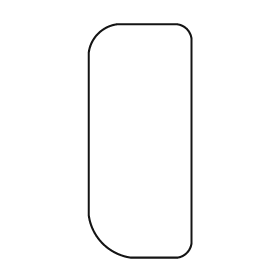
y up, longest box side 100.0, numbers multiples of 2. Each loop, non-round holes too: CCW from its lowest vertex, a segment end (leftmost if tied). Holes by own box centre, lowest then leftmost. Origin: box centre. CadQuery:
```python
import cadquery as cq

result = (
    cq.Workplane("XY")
    .moveTo(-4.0, -50.0)
    .lineTo(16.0, -50.0)
    .threePointArc((20.0, -48.0), (22.0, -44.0))
    .lineTo(22.0, 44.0)
    .threePointArc((20.0, 48.0), (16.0, 50.0))
    .lineTo(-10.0, 50.0)
    .threePointArc((-18.0, 46.0), (-22.0, 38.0))
    .lineTo(-22.0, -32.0)
    .threePointArc((-16.0, -44.0), (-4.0, -50.0))
    .close()
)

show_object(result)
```